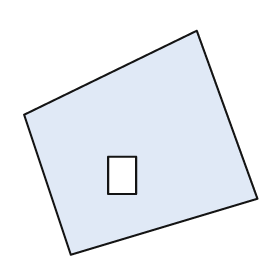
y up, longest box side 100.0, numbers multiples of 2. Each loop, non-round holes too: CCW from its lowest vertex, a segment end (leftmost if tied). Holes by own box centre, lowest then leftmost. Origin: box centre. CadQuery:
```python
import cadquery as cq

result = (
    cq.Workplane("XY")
    .moveTo(-30.0, -48.0)
    .lineTo(50.0, -24.0)
    .lineTo(24.0, 48.0)
    .lineTo(-50.0, 12.0)
    .close()
    .moveTo(-14.0, -22.0)
    .lineTo(-2.0, -22.0)
    .lineTo(-2.0, -6.0)
    .lineTo(-14.0, -6.0)
    .close()
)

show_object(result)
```